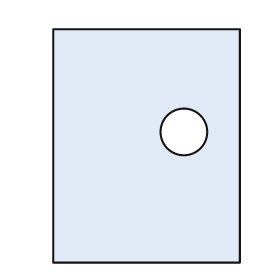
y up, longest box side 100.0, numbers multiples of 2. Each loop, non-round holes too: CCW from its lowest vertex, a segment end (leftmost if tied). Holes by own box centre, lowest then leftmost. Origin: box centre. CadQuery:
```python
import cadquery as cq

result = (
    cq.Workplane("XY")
    .moveTo(-40.0, -50.0)
    .lineTo(40.0, -50.0)
    .lineTo(40.0, 50.0)
    .lineTo(-40.0, 50.0)
    .close()
    .moveTo(16.0, 6.0)
    .circle(10.0)
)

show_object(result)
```